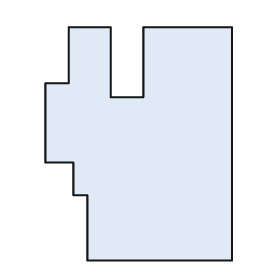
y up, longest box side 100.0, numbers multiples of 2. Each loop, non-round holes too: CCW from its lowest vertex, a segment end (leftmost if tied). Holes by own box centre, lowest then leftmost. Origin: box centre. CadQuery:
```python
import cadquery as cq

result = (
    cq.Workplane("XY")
    .moveTo(-22.0, -50.0)
    .lineTo(40.0, -50.0)
    .lineTo(40.0, 50.0)
    .lineTo(2.0, 50.0)
    .lineTo(2.0, 20.0)
    .lineTo(-12.0, 20.0)
    .lineTo(-12.0, 50.0)
    .lineTo(-30.0, 50.0)
    .lineTo(-30.0, 26.0)
    .lineTo(-40.0, 26.0)
    .lineTo(-40.0, -8.0)
    .lineTo(-28.0, -8.0)
    .lineTo(-28.0, -22.0)
    .lineTo(-22.0, -22.0)
    .close()
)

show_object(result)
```